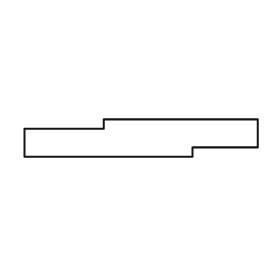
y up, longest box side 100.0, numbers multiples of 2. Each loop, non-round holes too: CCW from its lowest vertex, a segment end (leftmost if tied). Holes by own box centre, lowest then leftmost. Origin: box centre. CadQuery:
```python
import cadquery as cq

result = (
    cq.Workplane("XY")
    .moveTo(-50.0, -8.0)
    .lineTo(22.0, -8.0)
    .lineTo(22.0, -4.0)
    .lineTo(50.0, -4.0)
    .lineTo(50.0, 8.0)
    .lineTo(-16.0, 8.0)
    .lineTo(-16.0, 4.0)
    .lineTo(-50.0, 4.0)
    .close()
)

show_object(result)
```